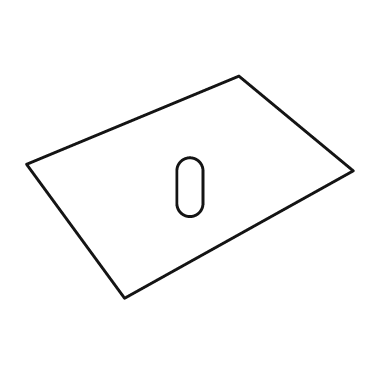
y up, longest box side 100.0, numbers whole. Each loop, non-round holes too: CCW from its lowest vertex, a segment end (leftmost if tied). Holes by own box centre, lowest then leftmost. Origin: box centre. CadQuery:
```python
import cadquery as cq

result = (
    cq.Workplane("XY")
    .moveTo(-20.0, -34.0)
    .lineTo(50.0, 5.0)
    .lineTo(15.0, 34.0)
    .lineTo(-50.0, 7.0)
    .close()
    .moveTo(-4.0, -5.0)
    .threePointArc((0.0, -9.0), (4.0, -5.0))
    .lineTo(4.0, 5.0)
    .threePointArc((0.0, 9.0), (-4.0, 5.0))
    .close()
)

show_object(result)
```